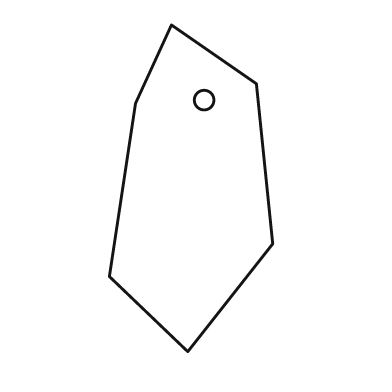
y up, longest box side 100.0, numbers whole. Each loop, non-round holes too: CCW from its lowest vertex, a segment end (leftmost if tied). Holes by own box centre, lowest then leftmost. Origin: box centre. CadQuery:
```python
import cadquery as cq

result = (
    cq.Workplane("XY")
    .moveTo(-1.0, -50.0)
    .lineTo(25.0, -17.0)
    .lineTo(20.0, 32.0)
    .lineTo(-6.0, 50.0)
    .lineTo(-17.0, 26.0)
    .lineTo(-25.0, -27.0)
    .close()
    .moveTo(4.0, 27.0)
    .circle(3.0)
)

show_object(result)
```